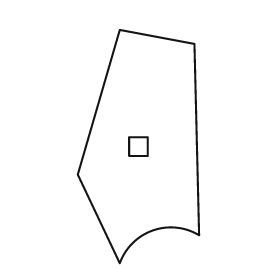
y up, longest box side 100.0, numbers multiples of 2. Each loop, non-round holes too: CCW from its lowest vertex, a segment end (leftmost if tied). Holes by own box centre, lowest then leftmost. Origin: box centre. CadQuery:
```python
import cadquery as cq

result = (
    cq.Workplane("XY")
    .moveTo(-8.0, -50.0)
    .threePointArc((6.0, -36.0), (26.0, -38.0))
    .lineTo(24.0, 44.0)
    .lineTo(-8.0, 50.0)
    .lineTo(-26.0, -12.0)
    .close()
    .moveTo(-4.0, -4.0)
    .lineTo(4.0, -4.0)
    .lineTo(4.0, 4.0)
    .lineTo(-4.0, 4.0)
    .close()
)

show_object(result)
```